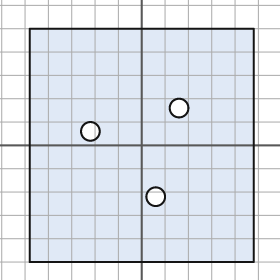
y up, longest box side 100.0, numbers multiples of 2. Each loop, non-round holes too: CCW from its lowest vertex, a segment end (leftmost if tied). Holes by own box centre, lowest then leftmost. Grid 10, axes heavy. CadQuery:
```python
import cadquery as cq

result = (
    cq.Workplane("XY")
    .moveTo(-48.0, -50.0)
    .lineTo(48.0, -50.0)
    .lineTo(48.0, 50.0)
    .lineTo(-48.0, 50.0)
    .close()
    .moveTo(6.0, -22.0)
    .circle(4.0)
    .moveTo(-22.0, 6.0)
    .circle(4.0)
    .moveTo(16.0, 16.0)
    .circle(4.0)
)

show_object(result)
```